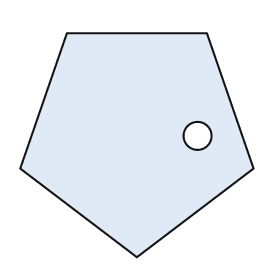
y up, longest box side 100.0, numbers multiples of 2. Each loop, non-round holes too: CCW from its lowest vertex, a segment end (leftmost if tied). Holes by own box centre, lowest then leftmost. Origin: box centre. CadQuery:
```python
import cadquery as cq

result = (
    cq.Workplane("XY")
    .moveTo(0.0, -48.0)
    .lineTo(50.0, -10.0)
    .lineTo(30.0, 48.0)
    .lineTo(-30.0, 48.0)
    .lineTo(-50.0, -10.0)
    .close()
    .moveTo(26.0, 4.0)
    .circle(6.0)
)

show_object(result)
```